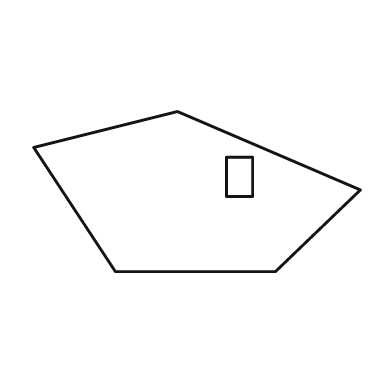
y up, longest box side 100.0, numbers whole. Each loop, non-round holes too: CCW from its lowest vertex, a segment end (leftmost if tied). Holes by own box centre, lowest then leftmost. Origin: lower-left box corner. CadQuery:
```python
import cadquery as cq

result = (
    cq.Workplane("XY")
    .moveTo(25.0, 0.0)
    .lineTo(74.0, 0.0)
    .lineTo(100.0, 25.0)
    .lineTo(44.0, 49.0)
    .lineTo(0.0, 38.0)
    .close()
    .moveTo(59.0, 23.0)
    .lineTo(67.0, 23.0)
    .lineTo(67.0, 35.0)
    .lineTo(59.0, 35.0)
    .close()
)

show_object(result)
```